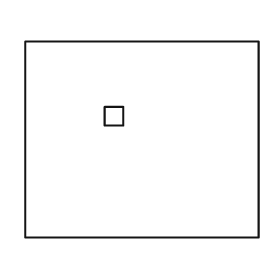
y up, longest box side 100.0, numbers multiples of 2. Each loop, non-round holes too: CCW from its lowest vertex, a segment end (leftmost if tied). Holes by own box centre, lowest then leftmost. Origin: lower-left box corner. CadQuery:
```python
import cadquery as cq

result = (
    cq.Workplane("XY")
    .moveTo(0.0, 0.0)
    .lineTo(100.0, 0.0)
    .lineTo(100.0, 84.0)
    .lineTo(0.0, 84.0)
    .close()
    .moveTo(34.0, 48.0)
    .lineTo(42.0, 48.0)
    .lineTo(42.0, 56.0)
    .lineTo(34.0, 56.0)
    .close()
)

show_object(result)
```